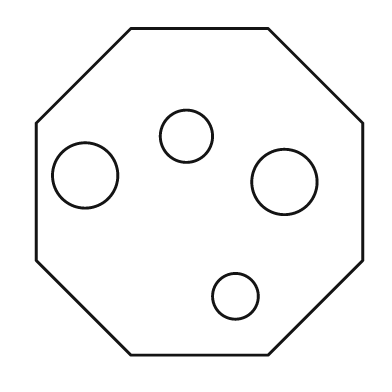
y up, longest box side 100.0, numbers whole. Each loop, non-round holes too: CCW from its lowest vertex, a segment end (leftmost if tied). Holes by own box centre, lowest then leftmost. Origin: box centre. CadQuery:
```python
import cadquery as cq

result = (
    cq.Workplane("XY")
    .moveTo(-21.0, -50.0)
    .lineTo(21.0, -50.0)
    .lineTo(50.0, -21.0)
    .lineTo(50.0, 21.0)
    .lineTo(21.0, 50.0)
    .lineTo(-21.0, 50.0)
    .lineTo(-50.0, 21.0)
    .lineTo(-50.0, -21.0)
    .close()
    .moveTo(11.0, -32.0)
    .circle(7.0)
    .moveTo(26.0, 3.0)
    .circle(10.0)
    .moveTo(-35.0, 5.0)
    .circle(10.0)
    .moveTo(-4.0, 17.0)
    .circle(8.0)
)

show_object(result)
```